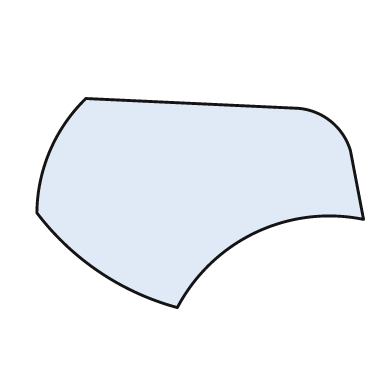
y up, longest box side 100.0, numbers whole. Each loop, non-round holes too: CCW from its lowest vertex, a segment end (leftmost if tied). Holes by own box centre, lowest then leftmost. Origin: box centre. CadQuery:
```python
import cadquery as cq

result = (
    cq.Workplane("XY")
    .moveTo(-7.0, -32.0)
    .threePointArc((17.0, -9.0), (50.0, -5.0))
    .lineTo(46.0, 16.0)
    .threePointArc((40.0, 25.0), (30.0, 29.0))
    .lineTo(-35.0, 32.0)
    .threePointArc((-46.0, 16.0), (-50.0, -3.0))
    .threePointArc((-31.0, -21.0), (-7.0, -32.0))
    .close()
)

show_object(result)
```